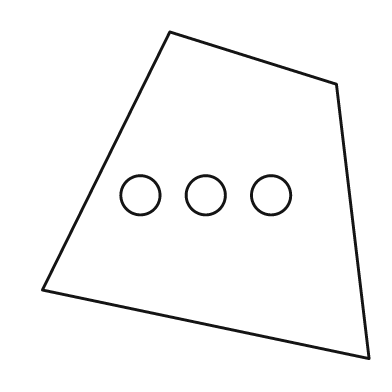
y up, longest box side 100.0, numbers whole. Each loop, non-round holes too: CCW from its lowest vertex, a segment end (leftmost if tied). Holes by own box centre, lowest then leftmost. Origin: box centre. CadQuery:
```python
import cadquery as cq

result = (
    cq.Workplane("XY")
    .moveTo(50.0, -50.0)
    .lineTo(40.0, 34.0)
    .lineTo(-11.0, 50.0)
    .lineTo(-50.0, -29.0)
    .close()
    .moveTo(-20.0, 0.0)
    .circle(6.0)
    .moveTo(0.0, 0.0)
    .circle(6.0)
    .moveTo(20.0, 0.0)
    .circle(6.0)
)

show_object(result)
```